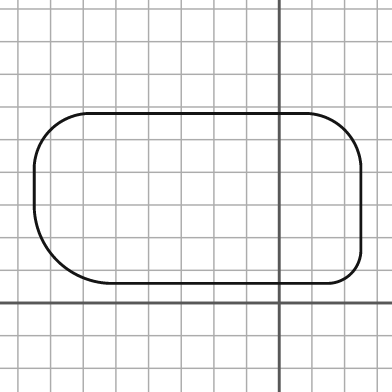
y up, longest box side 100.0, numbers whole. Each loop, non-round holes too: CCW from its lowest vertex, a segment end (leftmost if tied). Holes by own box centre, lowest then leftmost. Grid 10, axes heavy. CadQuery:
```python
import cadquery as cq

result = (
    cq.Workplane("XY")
    .moveTo(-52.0, 6.0)
    .lineTo(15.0, 6.0)
    .threePointArc((22.0, 9.0), (25.0, 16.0))
    .lineTo(25.0, 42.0)
    .threePointArc((20.0, 53.0), (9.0, 58.0))
    .lineTo(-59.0, 58.0)
    .threePointArc((-70.0, 53.0), (-75.0, 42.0))
    .lineTo(-75.0, 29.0)
    .threePointArc((-68.0, 13.0), (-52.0, 6.0))
    .close()
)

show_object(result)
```